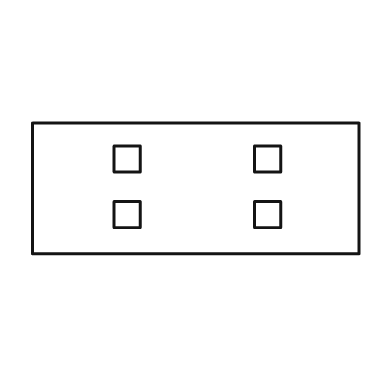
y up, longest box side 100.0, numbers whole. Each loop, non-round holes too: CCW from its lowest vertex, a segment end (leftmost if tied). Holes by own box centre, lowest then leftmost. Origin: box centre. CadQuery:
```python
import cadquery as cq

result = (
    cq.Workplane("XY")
    .moveTo(-50.0, -20.0)
    .lineTo(50.0, -20.0)
    .lineTo(50.0, 20.0)
    .lineTo(-50.0, 20.0)
    .close()
    .moveTo(-25.0, -12.0)
    .lineTo(-17.0, -12.0)
    .lineTo(-17.0, -4.0)
    .lineTo(-25.0, -4.0)
    .close()
    .moveTo(18.0, -12.0)
    .lineTo(26.0, -12.0)
    .lineTo(26.0, -4.0)
    .lineTo(18.0, -4.0)
    .close()
    .moveTo(-25.0, 5.0)
    .lineTo(-17.0, 5.0)
    .lineTo(-17.0, 13.0)
    .lineTo(-25.0, 13.0)
    .close()
    .moveTo(18.0, 5.0)
    .lineTo(26.0, 5.0)
    .lineTo(26.0, 13.0)
    .lineTo(18.0, 13.0)
    .close()
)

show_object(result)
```